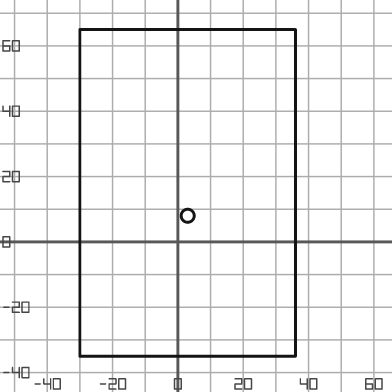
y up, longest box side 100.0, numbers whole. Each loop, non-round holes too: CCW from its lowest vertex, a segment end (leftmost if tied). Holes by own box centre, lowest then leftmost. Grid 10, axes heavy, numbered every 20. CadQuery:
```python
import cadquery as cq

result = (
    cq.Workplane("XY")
    .moveTo(-30.0, -35.0)
    .lineTo(36.0, -35.0)
    .lineTo(36.0, 65.0)
    .lineTo(-30.0, 65.0)
    .close()
    .moveTo(3.0, 8.0)
    .circle(2.0)
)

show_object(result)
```